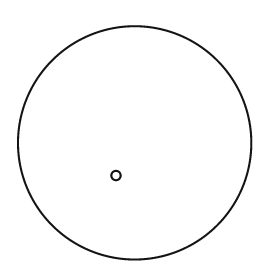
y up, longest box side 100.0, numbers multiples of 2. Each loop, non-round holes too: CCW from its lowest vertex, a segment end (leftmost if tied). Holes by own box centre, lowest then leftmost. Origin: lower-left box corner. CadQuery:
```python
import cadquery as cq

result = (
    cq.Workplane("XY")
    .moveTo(50.0, 50.0)
    .circle(50.0)
    .moveTo(42.0, 36.0)
    .circle(2.0)
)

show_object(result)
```